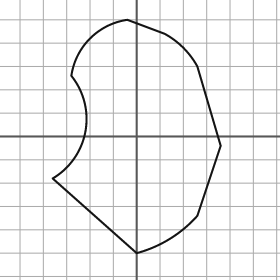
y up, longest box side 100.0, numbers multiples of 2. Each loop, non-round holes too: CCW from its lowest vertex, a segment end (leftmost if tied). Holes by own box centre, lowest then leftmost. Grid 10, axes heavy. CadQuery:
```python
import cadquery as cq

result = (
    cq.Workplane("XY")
    .moveTo(0.0, -50.0)
    .threePointArc((14.0, -44.0), (26.0, -34.0))
    .lineTo(36.0, -4.0)
    .lineTo(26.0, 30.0)
    .threePointArc((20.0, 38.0), (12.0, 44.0))
    .lineTo(-4.0, 50.0)
    .threePointArc((-20.0, 42.0), (-28.0, 26.0))
    .threePointArc((-22.0, 2.0), (-36.0, -18.0))
    .close()
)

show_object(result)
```